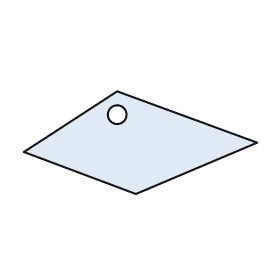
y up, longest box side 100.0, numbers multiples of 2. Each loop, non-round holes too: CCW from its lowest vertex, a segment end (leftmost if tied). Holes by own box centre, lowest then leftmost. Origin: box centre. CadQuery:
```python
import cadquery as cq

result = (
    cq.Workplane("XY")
    .moveTo(-2.0, -22.0)
    .lineTo(50.0, 0.0)
    .lineTo(-10.0, 22.0)
    .lineTo(-50.0, -4.0)
    .close()
    .moveTo(-10.0, 12.0)
    .circle(4.0)
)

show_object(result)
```